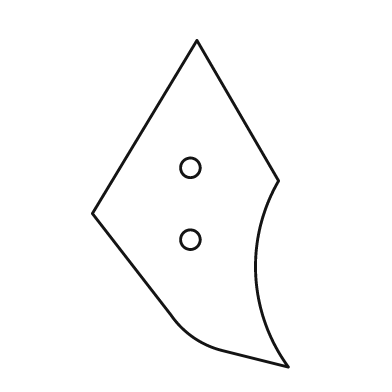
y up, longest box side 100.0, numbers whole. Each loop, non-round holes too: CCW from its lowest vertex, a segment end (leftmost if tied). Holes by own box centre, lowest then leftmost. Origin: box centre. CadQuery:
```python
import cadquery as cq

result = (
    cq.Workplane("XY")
    .moveTo(30.0, -50.0)
    .threePointArc((20.0, -22.0), (27.0, 7.0))
    .lineTo(2.0, 50.0)
    .lineTo(-30.0, -3.0)
    .lineTo(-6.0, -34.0)
    .threePointArc((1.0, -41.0), (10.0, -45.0))
    .close()
    .moveTo(0.0, -11.0)
    .circle(3.0)
    .moveTo(0.0, 11.0)
    .circle(3.0)
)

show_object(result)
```